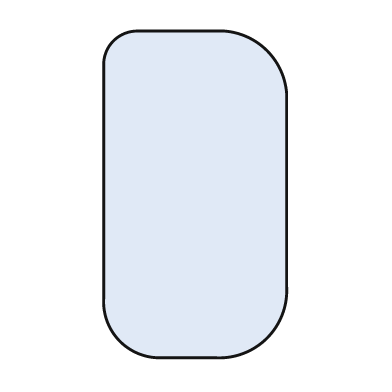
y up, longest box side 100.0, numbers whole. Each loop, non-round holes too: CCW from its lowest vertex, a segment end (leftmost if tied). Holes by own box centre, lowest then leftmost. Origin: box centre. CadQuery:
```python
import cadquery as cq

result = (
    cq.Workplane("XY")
    .moveTo(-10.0, -50.0)
    .lineTo(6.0, -50.0)
    .threePointArc((22.0, -44.0), (28.0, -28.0))
    .lineTo(28.0, 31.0)
    .threePointArc((22.0, 44.0), (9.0, 50.0))
    .lineTo(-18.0, 50.0)
    .threePointArc((-25.0, 47.0), (-28.0, 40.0))
    .lineTo(-28.0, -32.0)
    .threePointArc((-23.0, -45.0), (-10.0, -50.0))
    .close()
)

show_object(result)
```